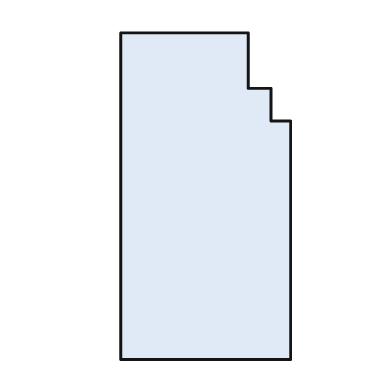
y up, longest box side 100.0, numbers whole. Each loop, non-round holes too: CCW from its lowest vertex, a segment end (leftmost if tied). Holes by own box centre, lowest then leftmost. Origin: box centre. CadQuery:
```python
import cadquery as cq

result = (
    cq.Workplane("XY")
    .moveTo(-26.0, -50.0)
    .lineTo(26.0, -50.0)
    .lineTo(26.0, 23.0)
    .lineTo(20.0, 23.0)
    .lineTo(20.0, 33.0)
    .lineTo(13.0, 33.0)
    .lineTo(13.0, 50.0)
    .lineTo(-26.0, 50.0)
    .close()
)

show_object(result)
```